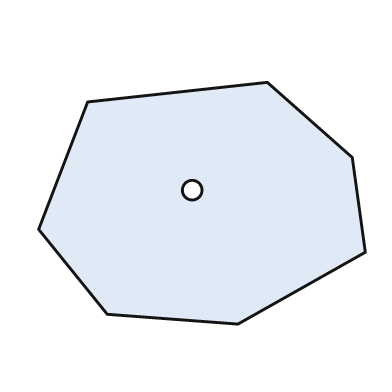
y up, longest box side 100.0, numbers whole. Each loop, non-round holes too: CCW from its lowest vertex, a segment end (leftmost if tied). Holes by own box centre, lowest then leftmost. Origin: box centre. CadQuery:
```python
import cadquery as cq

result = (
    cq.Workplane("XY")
    .moveTo(11.0, -37.0)
    .lineTo(50.0, -15.0)
    .lineTo(46.0, 14.0)
    .lineTo(20.0, 37.0)
    .lineTo(-35.0, 31.0)
    .lineTo(-50.0, -8.0)
    .lineTo(-29.0, -34.0)
    .close()
    .moveTo(-3.0, 4.0)
    .circle(3.0)
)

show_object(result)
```